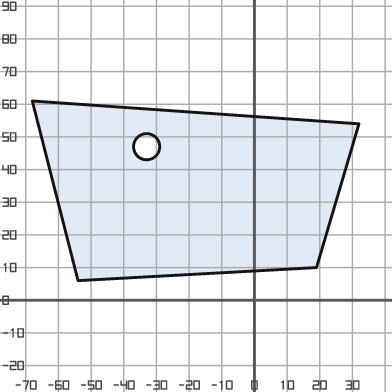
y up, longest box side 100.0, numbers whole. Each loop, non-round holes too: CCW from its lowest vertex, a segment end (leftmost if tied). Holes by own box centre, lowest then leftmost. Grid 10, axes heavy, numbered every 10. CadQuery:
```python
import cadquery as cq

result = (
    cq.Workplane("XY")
    .moveTo(-54.0, 6.0)
    .lineTo(19.0, 10.0)
    .lineTo(32.0, 54.0)
    .lineTo(-68.0, 61.0)
    .close()
    .moveTo(-33.0, 47.0)
    .circle(4.0)
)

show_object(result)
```